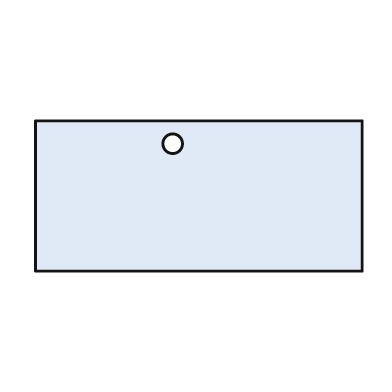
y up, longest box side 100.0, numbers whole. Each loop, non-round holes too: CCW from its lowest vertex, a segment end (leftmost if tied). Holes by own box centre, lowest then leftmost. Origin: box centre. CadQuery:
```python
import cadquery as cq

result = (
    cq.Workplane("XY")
    .moveTo(-50.0, -23.0)
    .lineTo(50.0, -23.0)
    .lineTo(50.0, 23.0)
    .lineTo(-50.0, 23.0)
    .close()
    .moveTo(-8.0, 16.0)
    .circle(3.0)
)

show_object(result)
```